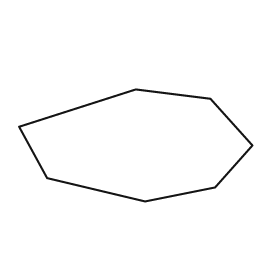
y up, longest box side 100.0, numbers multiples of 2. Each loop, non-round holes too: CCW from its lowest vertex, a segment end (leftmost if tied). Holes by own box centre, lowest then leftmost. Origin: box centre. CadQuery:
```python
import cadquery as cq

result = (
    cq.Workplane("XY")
    .moveTo(4.0, -24.0)
    .lineTo(34.0, -18.0)
    .lineTo(50.0, 0.0)
    .lineTo(32.0, 20.0)
    .lineTo(0.0, 24.0)
    .lineTo(-50.0, 8.0)
    .lineTo(-38.0, -14.0)
    .close()
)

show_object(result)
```